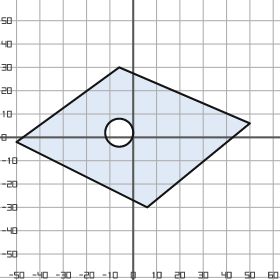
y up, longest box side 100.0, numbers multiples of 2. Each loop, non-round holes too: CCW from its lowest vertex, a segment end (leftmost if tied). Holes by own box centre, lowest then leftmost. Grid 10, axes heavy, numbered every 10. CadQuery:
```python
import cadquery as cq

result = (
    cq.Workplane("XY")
    .moveTo(6.0, -30.0)
    .lineTo(50.0, 6.0)
    .lineTo(-6.0, 30.0)
    .lineTo(-50.0, -2.0)
    .close()
    .moveTo(-6.0, 2.0)
    .circle(6.0)
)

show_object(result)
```